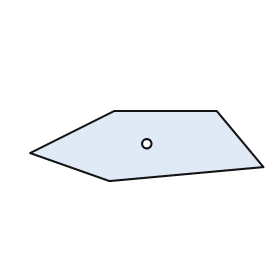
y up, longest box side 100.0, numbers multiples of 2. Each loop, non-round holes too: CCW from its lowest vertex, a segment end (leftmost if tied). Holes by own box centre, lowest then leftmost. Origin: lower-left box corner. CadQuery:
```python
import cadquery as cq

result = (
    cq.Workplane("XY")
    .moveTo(34.0, 0.0)
    .lineTo(100.0, 6.0)
    .lineTo(80.0, 30.0)
    .lineTo(36.0, 30.0)
    .lineTo(0.0, 12.0)
    .close()
    .moveTo(50.0, 16.0)
    .circle(2.0)
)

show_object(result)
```